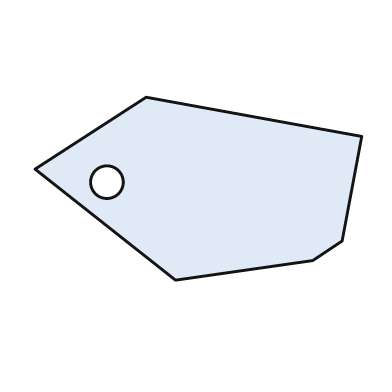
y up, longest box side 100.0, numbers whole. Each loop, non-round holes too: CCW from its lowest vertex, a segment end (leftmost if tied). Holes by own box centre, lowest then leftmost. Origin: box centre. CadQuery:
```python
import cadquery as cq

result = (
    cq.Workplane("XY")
    .moveTo(-7.0, -28.0)
    .lineTo(35.0, -22.0)
    .lineTo(44.0, -16.0)
    .lineTo(50.0, 16.0)
    .lineTo(-16.0, 28.0)
    .lineTo(-50.0, 6.0)
    .close()
    .moveTo(-28.0, 2.0)
    .circle(5.0)
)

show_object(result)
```